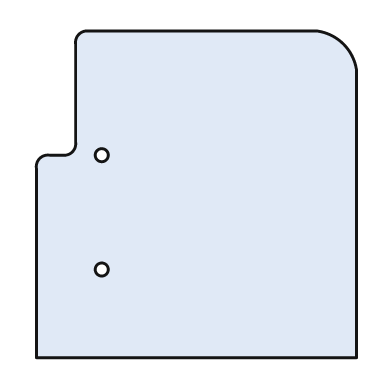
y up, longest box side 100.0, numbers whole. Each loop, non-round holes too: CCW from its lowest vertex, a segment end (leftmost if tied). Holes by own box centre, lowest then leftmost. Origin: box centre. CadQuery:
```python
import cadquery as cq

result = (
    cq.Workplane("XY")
    .moveTo(-49.0, -50.0)
    .lineTo(49.0, -50.0)
    .lineTo(49.0, 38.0)
    .threePointArc((45.0, 46.0), (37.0, 50.0))
    .lineTo(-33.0, 50.0)
    .threePointArc((-36.0, 49.0), (-37.0, 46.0))
    .lineTo(-37.0, 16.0)
    .threePointArc((-38.0, 13.0), (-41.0, 12.0))
    .lineTo(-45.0, 12.0)
    .threePointArc((-48.0, 11.0), (-49.0, 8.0))
    .close()
    .moveTo(-29.0, -23.0)
    .circle(2.0)
    .moveTo(-29.0, 12.0)
    .circle(2.0)
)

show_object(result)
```